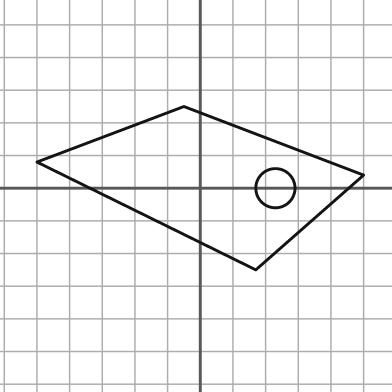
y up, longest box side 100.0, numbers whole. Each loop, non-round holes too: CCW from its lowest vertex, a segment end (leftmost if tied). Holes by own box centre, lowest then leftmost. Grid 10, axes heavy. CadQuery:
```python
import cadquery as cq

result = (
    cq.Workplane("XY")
    .moveTo(17.0, -25.0)
    .lineTo(50.0, 4.0)
    .lineTo(-5.0, 25.0)
    .lineTo(-50.0, 8.0)
    .close()
    .moveTo(23.0, 0.0)
    .circle(6.0)
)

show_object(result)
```